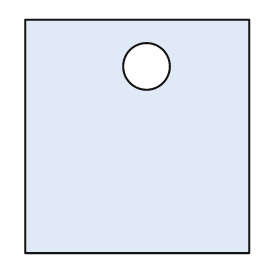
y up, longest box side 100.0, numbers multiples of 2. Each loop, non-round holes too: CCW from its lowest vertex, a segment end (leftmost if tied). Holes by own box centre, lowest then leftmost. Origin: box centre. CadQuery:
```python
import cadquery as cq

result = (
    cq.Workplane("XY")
    .moveTo(-48.0, -50.0)
    .lineTo(48.0, -50.0)
    .lineTo(48.0, 50.0)
    .lineTo(-48.0, 50.0)
    .close()
    .moveTo(4.0, 30.0)
    .circle(10.0)
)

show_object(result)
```